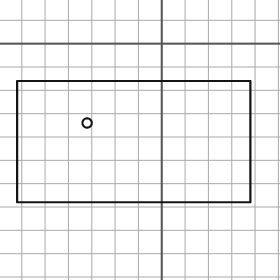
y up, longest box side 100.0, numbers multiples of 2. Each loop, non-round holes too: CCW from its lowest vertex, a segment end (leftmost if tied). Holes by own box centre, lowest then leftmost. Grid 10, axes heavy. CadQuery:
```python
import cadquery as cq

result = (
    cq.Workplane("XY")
    .moveTo(-62.0, -68.0)
    .lineTo(38.0, -68.0)
    .lineTo(38.0, -16.0)
    .lineTo(-62.0, -16.0)
    .close()
    .moveTo(-32.0, -34.0)
    .circle(2.0)
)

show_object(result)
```